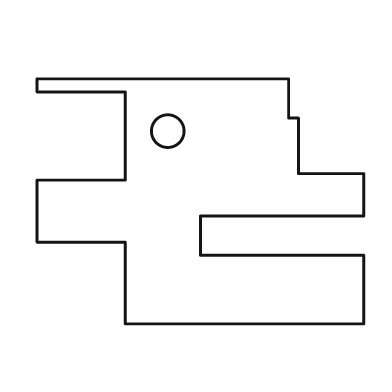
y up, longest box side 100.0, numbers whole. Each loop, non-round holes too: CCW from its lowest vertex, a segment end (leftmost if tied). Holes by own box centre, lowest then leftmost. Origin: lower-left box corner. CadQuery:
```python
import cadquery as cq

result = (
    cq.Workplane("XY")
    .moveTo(27.0, 0.0)
    .lineTo(100.0, 0.0)
    .lineTo(100.0, 21.0)
    .lineTo(50.0, 21.0)
    .lineTo(50.0, 33.0)
    .lineTo(100.0, 33.0)
    .lineTo(100.0, 46.0)
    .lineTo(80.0, 46.0)
    .lineTo(80.0, 63.0)
    .lineTo(77.0, 63.0)
    .lineTo(77.0, 75.0)
    .lineTo(0.0, 75.0)
    .lineTo(0.0, 71.0)
    .lineTo(27.0, 71.0)
    .lineTo(27.0, 44.0)
    .lineTo(0.0, 44.0)
    .lineTo(0.0, 25.0)
    .lineTo(27.0, 25.0)
    .close()
    .moveTo(40.0, 59.0)
    .circle(5.0)
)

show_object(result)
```